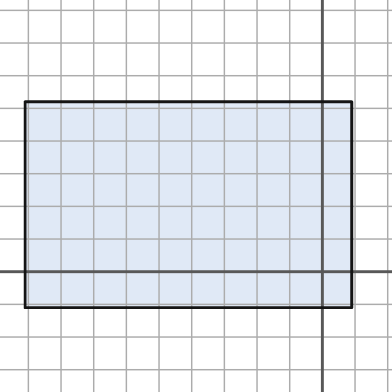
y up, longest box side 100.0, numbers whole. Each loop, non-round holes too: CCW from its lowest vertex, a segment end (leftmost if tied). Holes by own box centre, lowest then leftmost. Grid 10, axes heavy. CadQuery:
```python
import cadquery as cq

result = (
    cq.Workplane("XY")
    .moveTo(-91.0, -11.0)
    .lineTo(9.0, -11.0)
    .lineTo(9.0, 52.0)
    .lineTo(-91.0, 52.0)
    .close()
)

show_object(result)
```